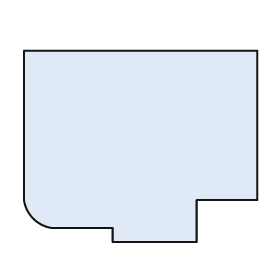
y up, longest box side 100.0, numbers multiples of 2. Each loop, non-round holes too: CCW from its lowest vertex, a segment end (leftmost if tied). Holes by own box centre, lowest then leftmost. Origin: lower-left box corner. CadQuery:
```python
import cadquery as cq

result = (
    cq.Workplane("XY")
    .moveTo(38.0, 0.0)
    .lineTo(74.0, 0.0)
    .lineTo(74.0, 18.0)
    .lineTo(100.0, 18.0)
    .lineTo(100.0, 82.0)
    .lineTo(0.0, 82.0)
    .lineTo(0.0, 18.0)
    .threePointArc((4.0, 10.0), (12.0, 6.0))
    .lineTo(38.0, 6.0)
    .close()
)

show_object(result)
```